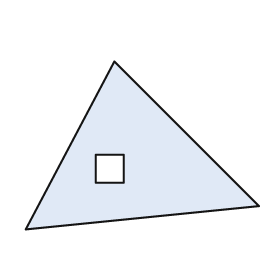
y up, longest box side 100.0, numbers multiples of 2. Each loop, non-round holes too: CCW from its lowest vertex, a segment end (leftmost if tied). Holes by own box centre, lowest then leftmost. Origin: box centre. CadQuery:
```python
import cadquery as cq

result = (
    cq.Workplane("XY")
    .moveTo(-50.0, -36.0)
    .lineTo(50.0, -26.0)
    .lineTo(-12.0, 36.0)
    .close()
    .moveTo(-20.0, -16.0)
    .lineTo(-8.0, -16.0)
    .lineTo(-8.0, -4.0)
    .lineTo(-20.0, -4.0)
    .close()
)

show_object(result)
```